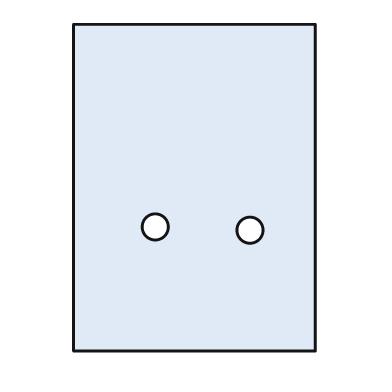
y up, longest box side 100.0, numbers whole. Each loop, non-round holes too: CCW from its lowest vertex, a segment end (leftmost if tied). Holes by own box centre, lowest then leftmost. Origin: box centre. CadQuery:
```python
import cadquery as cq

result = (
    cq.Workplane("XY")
    .moveTo(-37.0, -50.0)
    .lineTo(37.0, -50.0)
    .lineTo(37.0, 50.0)
    .lineTo(-37.0, 50.0)
    .close()
    .moveTo(17.0, -13.0)
    .circle(4.0)
    .moveTo(-12.0, -12.0)
    .circle(4.0)
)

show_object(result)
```